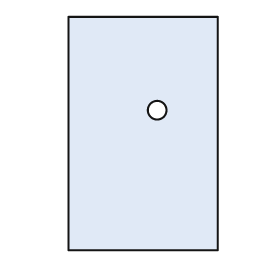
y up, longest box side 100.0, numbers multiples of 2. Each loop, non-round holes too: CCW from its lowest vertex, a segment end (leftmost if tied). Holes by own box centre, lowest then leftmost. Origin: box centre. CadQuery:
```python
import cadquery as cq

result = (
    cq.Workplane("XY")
    .moveTo(-32.0, -50.0)
    .lineTo(32.0, -50.0)
    .lineTo(32.0, 50.0)
    .lineTo(-32.0, 50.0)
    .close()
    .moveTo(6.0, 10.0)
    .circle(4.0)
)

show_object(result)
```